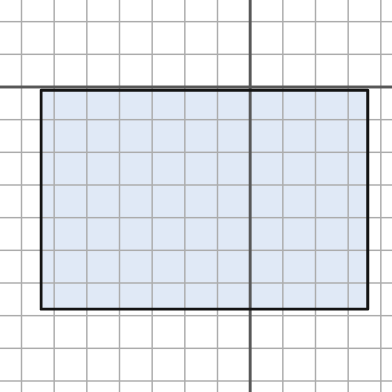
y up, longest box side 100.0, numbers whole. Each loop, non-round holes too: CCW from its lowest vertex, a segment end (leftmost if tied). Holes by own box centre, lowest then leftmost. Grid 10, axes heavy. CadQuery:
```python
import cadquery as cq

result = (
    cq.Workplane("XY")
    .moveTo(-64.0, -68.0)
    .lineTo(36.0, -68.0)
    .lineTo(36.0, -1.0)
    .lineTo(-64.0, -1.0)
    .close()
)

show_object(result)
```